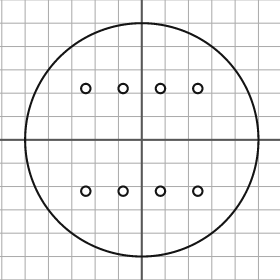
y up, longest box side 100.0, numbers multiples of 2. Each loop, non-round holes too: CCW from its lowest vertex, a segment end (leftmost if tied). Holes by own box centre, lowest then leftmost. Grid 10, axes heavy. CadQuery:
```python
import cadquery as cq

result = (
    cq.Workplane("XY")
    .moveTo(0.0, 0.0)
    .circle(50.0)
    .moveTo(-24.0, -22.0)
    .circle(2.0)
    .moveTo(-8.0, -22.0)
    .circle(2.0)
    .moveTo(8.0, -22.0)
    .circle(2.0)
    .moveTo(24.0, -22.0)
    .circle(2.0)
    .moveTo(-24.0, 22.0)
    .circle(2.0)
    .moveTo(-8.0, 22.0)
    .circle(2.0)
    .moveTo(8.0, 22.0)
    .circle(2.0)
    .moveTo(24.0, 22.0)
    .circle(2.0)
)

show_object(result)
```